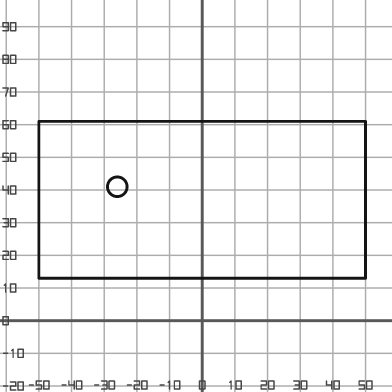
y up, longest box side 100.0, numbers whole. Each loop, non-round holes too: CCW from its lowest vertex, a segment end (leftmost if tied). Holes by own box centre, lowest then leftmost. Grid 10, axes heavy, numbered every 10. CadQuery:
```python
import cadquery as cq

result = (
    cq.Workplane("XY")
    .moveTo(-50.0, 13.0)
    .lineTo(50.0, 13.0)
    .lineTo(50.0, 61.0)
    .lineTo(-50.0, 61.0)
    .close()
    .moveTo(-26.0, 41.0)
    .circle(3.0)
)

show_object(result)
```